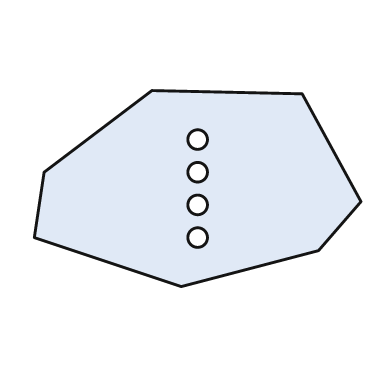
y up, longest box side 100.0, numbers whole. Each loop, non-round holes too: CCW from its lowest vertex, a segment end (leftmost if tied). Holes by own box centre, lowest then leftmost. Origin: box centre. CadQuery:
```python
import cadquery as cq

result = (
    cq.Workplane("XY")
    .moveTo(-5.0, -30.0)
    .lineTo(37.0, -19.0)
    .lineTo(50.0, -4.0)
    .lineTo(32.0, 29.0)
    .lineTo(-14.0, 30.0)
    .lineTo(-47.0, 5.0)
    .lineTo(-50.0, -15.0)
    .close()
    .moveTo(0.0, -15.0)
    .circle(3.0)
    .moveTo(0.0, -5.0)
    .circle(3.0)
    .moveTo(0.0, 5.0)
    .circle(3.0)
    .moveTo(0.0, 15.0)
    .circle(3.0)
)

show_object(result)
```